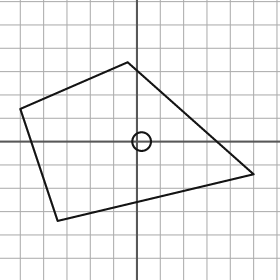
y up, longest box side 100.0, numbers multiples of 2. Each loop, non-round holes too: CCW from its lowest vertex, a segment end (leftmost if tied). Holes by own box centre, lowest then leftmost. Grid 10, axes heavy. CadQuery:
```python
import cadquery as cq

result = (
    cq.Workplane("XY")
    .moveTo(-34.0, -34.0)
    .lineTo(50.0, -14.0)
    .lineTo(-4.0, 34.0)
    .lineTo(-50.0, 14.0)
    .close()
    .moveTo(2.0, 0.0)
    .circle(4.0)
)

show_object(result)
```